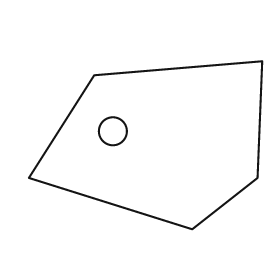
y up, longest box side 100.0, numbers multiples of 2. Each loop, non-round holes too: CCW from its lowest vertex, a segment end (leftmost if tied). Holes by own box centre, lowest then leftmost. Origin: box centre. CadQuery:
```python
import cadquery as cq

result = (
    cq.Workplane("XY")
    .moveTo(20.0, -36.0)
    .lineTo(48.0, -14.0)
    .lineTo(50.0, 36.0)
    .lineTo(-22.0, 30.0)
    .lineTo(-50.0, -14.0)
    .close()
    .moveTo(-14.0, 6.0)
    .circle(6.0)
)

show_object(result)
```